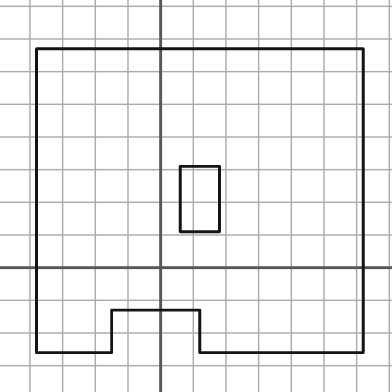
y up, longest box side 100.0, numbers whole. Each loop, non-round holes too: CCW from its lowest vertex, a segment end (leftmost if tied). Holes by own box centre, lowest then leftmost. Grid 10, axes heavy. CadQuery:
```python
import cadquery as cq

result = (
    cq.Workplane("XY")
    .moveTo(-38.0, -26.0)
    .lineTo(-15.0, -26.0)
    .lineTo(-15.0, -13.0)
    .lineTo(12.0, -13.0)
    .lineTo(12.0, -26.0)
    .lineTo(62.0, -26.0)
    .lineTo(62.0, 67.0)
    .lineTo(-38.0, 67.0)
    .close()
    .moveTo(6.0, 11.0)
    .lineTo(18.0, 11.0)
    .lineTo(18.0, 31.0)
    .lineTo(6.0, 31.0)
    .close()
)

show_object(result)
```